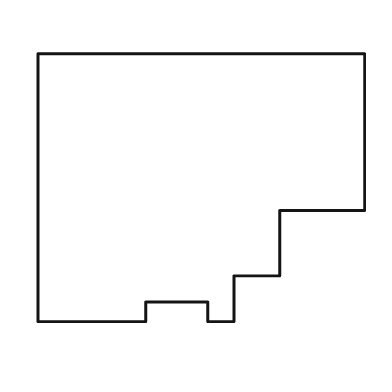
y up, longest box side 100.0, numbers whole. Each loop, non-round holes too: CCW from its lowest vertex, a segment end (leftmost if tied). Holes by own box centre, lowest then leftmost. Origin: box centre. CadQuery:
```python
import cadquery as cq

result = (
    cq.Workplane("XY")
    .moveTo(-50.0, -41.0)
    .lineTo(-17.0, -41.0)
    .lineTo(-17.0, -35.0)
    .lineTo(2.0, -35.0)
    .lineTo(2.0, -41.0)
    .lineTo(10.0, -41.0)
    .lineTo(10.0, -27.0)
    .lineTo(24.0, -27.0)
    .lineTo(24.0, -7.0)
    .lineTo(50.0, -7.0)
    .lineTo(50.0, 41.0)
    .lineTo(-50.0, 41.0)
    .close()
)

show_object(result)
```